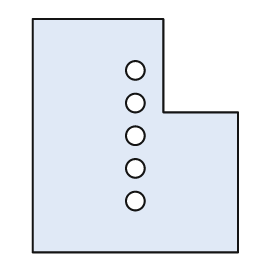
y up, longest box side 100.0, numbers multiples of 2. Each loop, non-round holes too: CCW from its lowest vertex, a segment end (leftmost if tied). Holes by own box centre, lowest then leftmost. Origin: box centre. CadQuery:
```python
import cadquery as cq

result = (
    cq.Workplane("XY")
    .moveTo(-44.0, -50.0)
    .lineTo(44.0, -50.0)
    .lineTo(44.0, 10.0)
    .lineTo(12.0, 10.0)
    .lineTo(12.0, 50.0)
    .lineTo(-44.0, 50.0)
    .close()
    .moveTo(0.0, -28.0)
    .circle(4.0)
    .moveTo(0.0, -14.0)
    .circle(4.0)
    .moveTo(0.0, 0.0)
    .circle(4.0)
    .moveTo(0.0, 14.0)
    .circle(4.0)
    .moveTo(0.0, 28.0)
    .circle(4.0)
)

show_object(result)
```